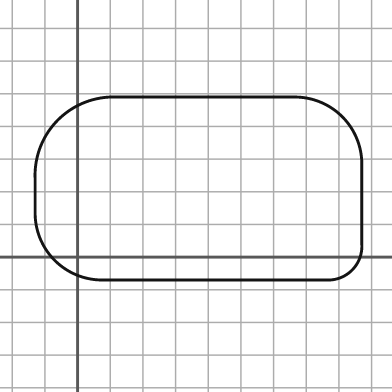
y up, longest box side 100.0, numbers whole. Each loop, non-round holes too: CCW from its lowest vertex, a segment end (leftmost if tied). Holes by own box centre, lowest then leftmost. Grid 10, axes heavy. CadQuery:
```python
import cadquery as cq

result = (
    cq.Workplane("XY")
    .moveTo(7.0, -7.0)
    .lineTo(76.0, -7.0)
    .threePointArc((84.0, -4.0), (87.0, 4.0))
    .lineTo(87.0, 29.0)
    .threePointArc((81.0, 43.0), (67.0, 49.0))
    .lineTo(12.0, 49.0)
    .threePointArc((-6.0, 42.0), (-13.0, 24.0))
    .lineTo(-13.0, 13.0)
    .threePointArc((-7.0, -1.0), (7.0, -7.0))
    .close()
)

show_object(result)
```